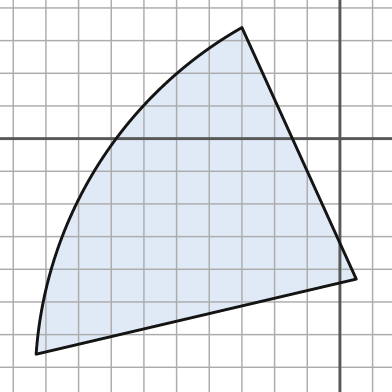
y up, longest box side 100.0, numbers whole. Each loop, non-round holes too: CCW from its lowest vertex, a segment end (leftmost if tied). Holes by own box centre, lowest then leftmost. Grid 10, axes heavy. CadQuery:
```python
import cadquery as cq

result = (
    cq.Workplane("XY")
    .moveTo(-93.0, -66.0)
    .lineTo(5.0, -43.0)
    .lineTo(-30.0, 34.0)
    .threePointArc((-74.0, -8.0), (-93.0, -66.0))
    .close()
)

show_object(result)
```